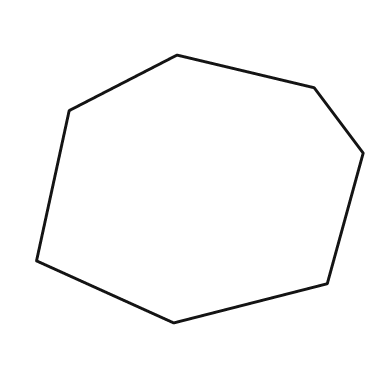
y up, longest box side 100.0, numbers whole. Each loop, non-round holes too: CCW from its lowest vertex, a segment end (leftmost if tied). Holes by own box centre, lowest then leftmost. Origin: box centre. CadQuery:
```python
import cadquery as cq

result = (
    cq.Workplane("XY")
    .moveTo(-8.0, -41.0)
    .lineTo(39.0, -29.0)
    .lineTo(50.0, 11.0)
    .lineTo(35.0, 31.0)
    .lineTo(-7.0, 41.0)
    .lineTo(-40.0, 24.0)
    .lineTo(-50.0, -22.0)
    .close()
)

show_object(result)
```